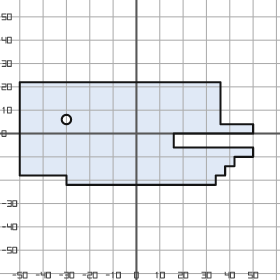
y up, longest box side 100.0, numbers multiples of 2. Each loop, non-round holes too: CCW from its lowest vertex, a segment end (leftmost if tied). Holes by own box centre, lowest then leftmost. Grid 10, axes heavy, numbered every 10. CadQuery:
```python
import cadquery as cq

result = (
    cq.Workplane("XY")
    .moveTo(-30.0, -22.0)
    .lineTo(34.0, -22.0)
    .lineTo(34.0, -18.0)
    .lineTo(38.0, -18.0)
    .lineTo(38.0, -14.0)
    .lineTo(42.0, -14.0)
    .lineTo(42.0, -10.0)
    .lineTo(50.0, -10.0)
    .lineTo(50.0, -6.0)
    .lineTo(16.0, -6.0)
    .lineTo(16.0, 0.0)
    .lineTo(50.0, 0.0)
    .lineTo(50.0, 4.0)
    .lineTo(36.0, 4.0)
    .lineTo(36.0, 22.0)
    .lineTo(-50.0, 22.0)
    .lineTo(-50.0, -18.0)
    .lineTo(-30.0, -18.0)
    .close()
    .moveTo(-30.0, 6.0)
    .circle(2.0)
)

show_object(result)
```